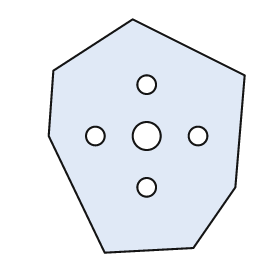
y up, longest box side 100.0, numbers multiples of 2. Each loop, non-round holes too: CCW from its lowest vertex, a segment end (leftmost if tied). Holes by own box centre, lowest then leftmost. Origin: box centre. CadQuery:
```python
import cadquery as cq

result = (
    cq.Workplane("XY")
    .moveTo(-18.0, -50.0)
    .lineTo(20.0, -48.0)
    .lineTo(38.0, -22.0)
    .lineTo(42.0, 26.0)
    .lineTo(-6.0, 50.0)
    .lineTo(-40.0, 28.0)
    .lineTo(-42.0, 0.0)
    .close()
    .moveTo(0.0, -22.0)
    .circle(4.0)
    .moveTo(-22.0, 0.0)
    .circle(4.0)
    .moveTo(0.0, 0.0)
    .circle(6.0)
    .moveTo(22.0, 0.0)
    .circle(4.0)
    .moveTo(0.0, 22.0)
    .circle(4.0)
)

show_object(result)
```